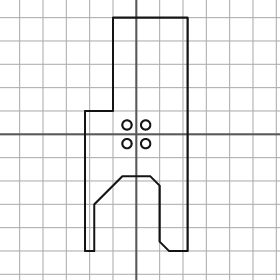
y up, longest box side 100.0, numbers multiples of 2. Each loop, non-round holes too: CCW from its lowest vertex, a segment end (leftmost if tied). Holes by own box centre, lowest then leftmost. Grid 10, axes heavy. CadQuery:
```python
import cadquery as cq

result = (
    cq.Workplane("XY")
    .moveTo(-22.0, -50.0)
    .lineTo(-18.0, -50.0)
    .lineTo(-18.0, -30.0)
    .lineTo(-6.0, -18.0)
    .lineTo(6.0, -18.0)
    .lineTo(10.0, -22.0)
    .lineTo(10.0, -46.0)
    .lineTo(14.0, -50.0)
    .lineTo(22.0, -50.0)
    .lineTo(22.0, 50.0)
    .lineTo(-10.0, 50.0)
    .lineTo(-10.0, 10.0)
    .lineTo(-22.0, 10.0)
    .close()
    .moveTo(-4.0, -4.0)
    .circle(2.0)
    .moveTo(4.0, -4.0)
    .circle(2.0)
    .moveTo(-4.0, 4.0)
    .circle(2.0)
    .moveTo(4.0, 4.0)
    .circle(2.0)
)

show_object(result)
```